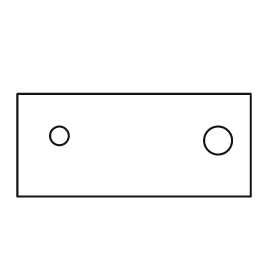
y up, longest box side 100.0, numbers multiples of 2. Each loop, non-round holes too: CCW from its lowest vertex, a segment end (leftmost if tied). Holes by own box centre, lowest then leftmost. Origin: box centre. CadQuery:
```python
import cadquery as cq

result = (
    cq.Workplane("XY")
    .moveTo(-50.0, -22.0)
    .lineTo(50.0, -22.0)
    .lineTo(50.0, 22.0)
    .lineTo(-50.0, 22.0)
    .close()
    .moveTo(36.0, 2.0)
    .circle(6.0)
    .moveTo(-32.0, 4.0)
    .circle(4.0)
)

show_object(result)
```